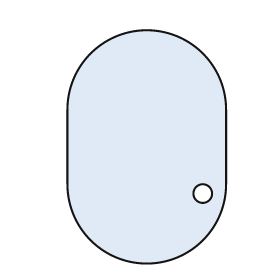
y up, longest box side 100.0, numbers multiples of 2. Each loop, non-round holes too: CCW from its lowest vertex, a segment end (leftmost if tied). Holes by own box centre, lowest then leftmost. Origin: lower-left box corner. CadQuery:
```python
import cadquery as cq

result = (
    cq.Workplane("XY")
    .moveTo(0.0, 34.0)
    .threePointArc((34.0, 0.0), (68.0, 34.0))
    .lineTo(68.0, 66.0)
    .threePointArc((34.0, 100.0), (0.0, 66.0))
    .close()
    .moveTo(58.0, 30.0)
    .circle(4.0)
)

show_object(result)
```